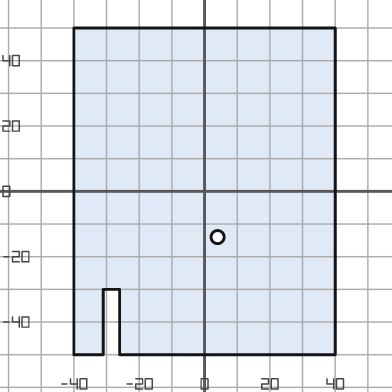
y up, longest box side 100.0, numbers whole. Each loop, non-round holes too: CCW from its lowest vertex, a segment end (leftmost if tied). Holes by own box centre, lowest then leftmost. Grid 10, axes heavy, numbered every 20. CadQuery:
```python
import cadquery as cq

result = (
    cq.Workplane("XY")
    .moveTo(-40.0, -50.0)
    .lineTo(-31.0, -50.0)
    .lineTo(-31.0, -30.0)
    .lineTo(-26.0, -30.0)
    .lineTo(-26.0, -50.0)
    .lineTo(40.0, -50.0)
    .lineTo(40.0, 50.0)
    .lineTo(-40.0, 50.0)
    .close()
    .moveTo(4.0, -14.0)
    .circle(2.0)
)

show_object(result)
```